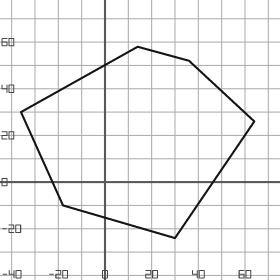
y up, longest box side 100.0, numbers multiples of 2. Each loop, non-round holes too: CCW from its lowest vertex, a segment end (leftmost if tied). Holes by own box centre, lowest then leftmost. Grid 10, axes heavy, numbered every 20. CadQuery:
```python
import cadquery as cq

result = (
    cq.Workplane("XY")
    .moveTo(30.0, -24.0)
    .lineTo(64.0, 26.0)
    .lineTo(36.0, 52.0)
    .lineTo(14.0, 58.0)
    .lineTo(-36.0, 30.0)
    .lineTo(-18.0, -10.0)
    .close()
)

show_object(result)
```